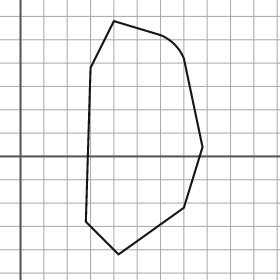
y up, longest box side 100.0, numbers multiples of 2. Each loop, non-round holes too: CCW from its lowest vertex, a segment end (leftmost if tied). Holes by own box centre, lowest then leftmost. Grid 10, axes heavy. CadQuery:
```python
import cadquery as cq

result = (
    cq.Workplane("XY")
    .moveTo(42.0, -42.0)
    .lineTo(70.0, -22.0)
    .lineTo(78.0, 4.0)
    .lineTo(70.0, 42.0)
    .threePointArc((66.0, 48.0), (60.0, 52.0))
    .lineTo(40.0, 58.0)
    .lineTo(30.0, 38.0)
    .lineTo(28.0, -28.0)
    .close()
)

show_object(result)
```